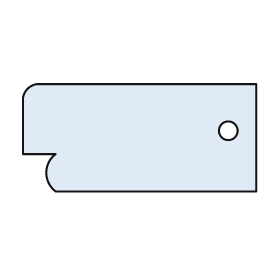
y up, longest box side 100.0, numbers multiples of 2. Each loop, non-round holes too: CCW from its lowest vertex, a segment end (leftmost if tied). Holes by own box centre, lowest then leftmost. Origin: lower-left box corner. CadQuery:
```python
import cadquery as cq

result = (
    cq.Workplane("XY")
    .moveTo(14.0, 0.0)
    .lineTo(100.0, 0.0)
    .lineTo(100.0, 46.0)
    .lineTo(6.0, 46.0)
    .threePointArc((2.0, 44.0), (0.0, 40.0))
    .lineTo(0.0, 16.0)
    .lineTo(14.0, 16.0)
    .threePointArc((10.0, 8.0), (14.0, 0.0))
    .close()
    .moveTo(88.0, 26.0)
    .circle(4.0)
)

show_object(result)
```